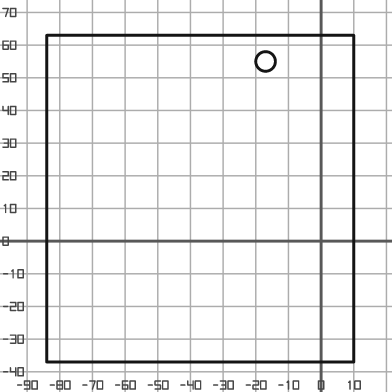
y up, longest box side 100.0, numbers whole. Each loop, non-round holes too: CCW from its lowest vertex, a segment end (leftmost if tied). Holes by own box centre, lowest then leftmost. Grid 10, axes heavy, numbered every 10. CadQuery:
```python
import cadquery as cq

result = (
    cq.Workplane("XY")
    .moveTo(-84.0, -37.0)
    .lineTo(10.0, -37.0)
    .lineTo(10.0, 63.0)
    .lineTo(-84.0, 63.0)
    .close()
    .moveTo(-17.0, 55.0)
    .circle(3.0)
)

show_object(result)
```